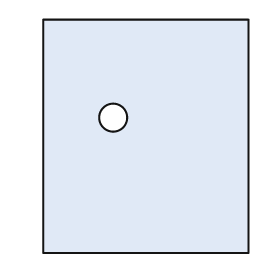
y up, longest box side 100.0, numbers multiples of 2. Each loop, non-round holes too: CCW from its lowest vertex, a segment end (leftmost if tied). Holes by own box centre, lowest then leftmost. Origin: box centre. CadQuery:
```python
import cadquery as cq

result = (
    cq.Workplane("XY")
    .moveTo(-44.0, -50.0)
    .lineTo(44.0, -50.0)
    .lineTo(44.0, 50.0)
    .lineTo(-44.0, 50.0)
    .close()
    .moveTo(-14.0, 8.0)
    .circle(6.0)
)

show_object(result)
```